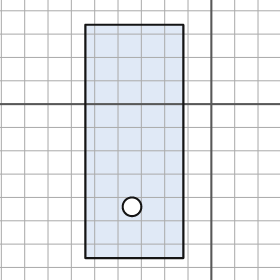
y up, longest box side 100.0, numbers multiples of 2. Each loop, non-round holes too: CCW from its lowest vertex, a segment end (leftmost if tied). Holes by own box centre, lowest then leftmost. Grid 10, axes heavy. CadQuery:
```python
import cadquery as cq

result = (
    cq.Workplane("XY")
    .moveTo(-54.0, -66.0)
    .lineTo(-12.0, -66.0)
    .lineTo(-12.0, 34.0)
    .lineTo(-54.0, 34.0)
    .close()
    .moveTo(-34.0, -44.0)
    .circle(4.0)
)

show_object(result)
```